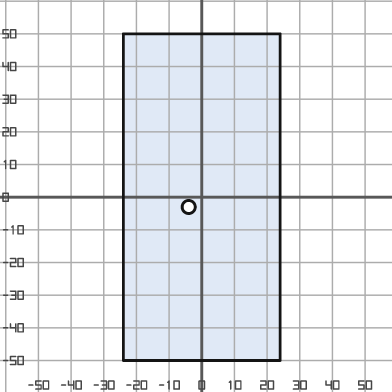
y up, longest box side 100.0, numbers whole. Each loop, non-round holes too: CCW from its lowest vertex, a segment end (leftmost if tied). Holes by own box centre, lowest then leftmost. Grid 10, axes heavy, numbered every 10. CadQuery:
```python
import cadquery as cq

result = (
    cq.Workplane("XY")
    .moveTo(-24.0, -50.0)
    .lineTo(24.0, -50.0)
    .lineTo(24.0, 50.0)
    .lineTo(-24.0, 50.0)
    .close()
    .moveTo(-4.0, -3.0)
    .circle(2.0)
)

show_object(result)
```